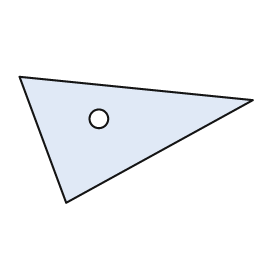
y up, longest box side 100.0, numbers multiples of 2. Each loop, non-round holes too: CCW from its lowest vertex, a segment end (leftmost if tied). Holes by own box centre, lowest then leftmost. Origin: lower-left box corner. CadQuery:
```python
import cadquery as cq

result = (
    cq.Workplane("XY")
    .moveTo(20.0, 0.0)
    .lineTo(100.0, 44.0)
    .lineTo(0.0, 54.0)
    .close()
    .moveTo(34.0, 36.0)
    .circle(4.0)
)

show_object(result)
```